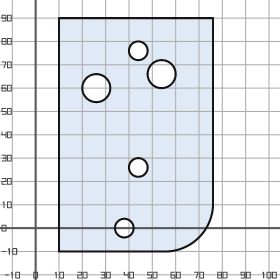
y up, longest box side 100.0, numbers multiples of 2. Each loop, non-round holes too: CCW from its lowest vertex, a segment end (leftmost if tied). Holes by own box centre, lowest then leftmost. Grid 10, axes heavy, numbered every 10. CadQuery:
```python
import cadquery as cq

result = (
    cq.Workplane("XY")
    .moveTo(10.0, -10.0)
    .lineTo(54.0, -10.0)
    .threePointArc((70.0, -4.0), (76.0, 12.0))
    .lineTo(76.0, 90.0)
    .lineTo(10.0, 90.0)
    .close()
    .moveTo(38.0, 0.0)
    .circle(4.0)
    .moveTo(44.0, 26.0)
    .circle(4.0)
    .moveTo(26.0, 60.0)
    .circle(6.0)
    .moveTo(54.0, 66.0)
    .circle(6.0)
    .moveTo(44.0, 76.0)
    .circle(4.0)
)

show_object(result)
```